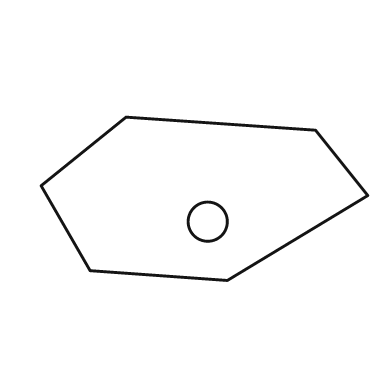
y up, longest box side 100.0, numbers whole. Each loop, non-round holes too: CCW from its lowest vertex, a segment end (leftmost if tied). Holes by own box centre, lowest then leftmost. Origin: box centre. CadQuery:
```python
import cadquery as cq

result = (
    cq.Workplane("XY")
    .moveTo(7.0, -25.0)
    .lineTo(50.0, 1.0)
    .lineTo(34.0, 21.0)
    .lineTo(-24.0, 25.0)
    .lineTo(-50.0, 4.0)
    .lineTo(-35.0, -22.0)
    .close()
    .moveTo(1.0, -7.0)
    .circle(6.0)
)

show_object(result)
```